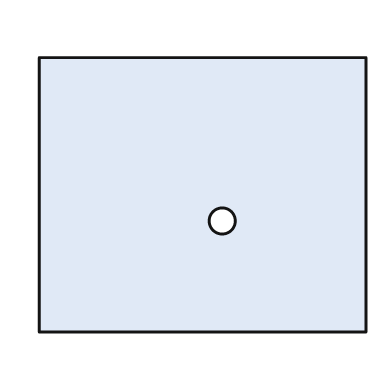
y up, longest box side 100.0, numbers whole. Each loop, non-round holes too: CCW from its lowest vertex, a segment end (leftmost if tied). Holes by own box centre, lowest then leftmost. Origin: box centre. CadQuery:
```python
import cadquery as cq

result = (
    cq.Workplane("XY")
    .moveTo(-50.0, -42.0)
    .lineTo(50.0, -42.0)
    .lineTo(50.0, 42.0)
    .lineTo(-50.0, 42.0)
    .close()
    .moveTo(6.0, -8.0)
    .circle(4.0)
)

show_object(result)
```